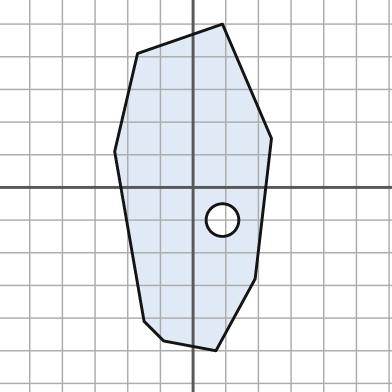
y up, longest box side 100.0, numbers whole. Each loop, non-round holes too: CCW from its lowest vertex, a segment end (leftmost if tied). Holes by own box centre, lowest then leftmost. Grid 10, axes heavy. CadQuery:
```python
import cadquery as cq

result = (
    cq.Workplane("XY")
    .moveTo(7.0, -50.0)
    .lineTo(19.0, -28.0)
    .lineTo(24.0, 15.0)
    .lineTo(9.0, 50.0)
    .lineTo(-17.0, 41.0)
    .lineTo(-24.0, 11.0)
    .lineTo(-15.0, -41.0)
    .lineTo(-9.0, -47.0)
    .close()
    .moveTo(9.0, -10.0)
    .circle(5.0)
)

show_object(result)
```